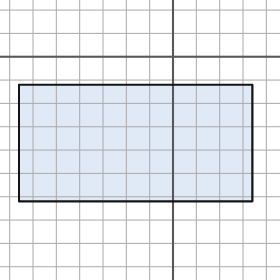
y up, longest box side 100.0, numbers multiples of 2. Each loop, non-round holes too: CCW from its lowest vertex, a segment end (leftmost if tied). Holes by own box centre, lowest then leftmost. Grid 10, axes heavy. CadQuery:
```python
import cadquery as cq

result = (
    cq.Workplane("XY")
    .moveTo(-66.0, -62.0)
    .lineTo(34.0, -62.0)
    .lineTo(34.0, -12.0)
    .lineTo(-66.0, -12.0)
    .close()
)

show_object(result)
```